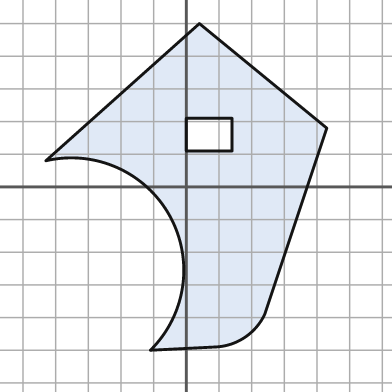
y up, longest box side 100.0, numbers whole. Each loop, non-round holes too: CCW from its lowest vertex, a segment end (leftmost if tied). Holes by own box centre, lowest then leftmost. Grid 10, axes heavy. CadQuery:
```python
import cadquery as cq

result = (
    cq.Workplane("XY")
    .moveTo(-11.0, -50.0)
    .lineTo(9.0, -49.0)
    .threePointArc((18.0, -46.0), (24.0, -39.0))
    .lineTo(43.0, 18.0)
    .lineTo(4.0, 50.0)
    .lineTo(-43.0, 8.0)
    .threePointArc((-5.0, -9.0), (-11.0, -50.0))
    .close()
    .moveTo(0.0, 11.0)
    .lineTo(14.0, 11.0)
    .lineTo(14.0, 21.0)
    .lineTo(0.0, 21.0)
    .close()
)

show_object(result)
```